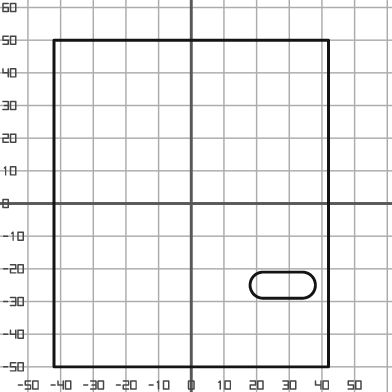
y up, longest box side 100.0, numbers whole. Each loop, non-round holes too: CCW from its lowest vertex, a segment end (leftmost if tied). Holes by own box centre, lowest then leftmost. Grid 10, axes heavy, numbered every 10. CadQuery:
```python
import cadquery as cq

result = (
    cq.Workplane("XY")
    .moveTo(-42.0, -50.0)
    .lineTo(42.0, -50.0)
    .lineTo(42.0, 50.0)
    .lineTo(-42.0, 50.0)
    .close()
    .moveTo(22.0, -29.0)
    .lineTo(34.0, -29.0)
    .threePointArc((38.0, -25.0), (34.0, -21.0))
    .lineTo(22.0, -21.0)
    .threePointArc((18.0, -25.0), (22.0, -29.0))
    .close()
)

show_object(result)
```